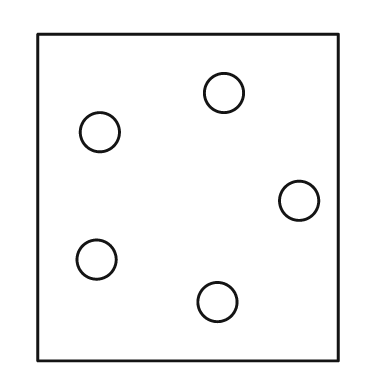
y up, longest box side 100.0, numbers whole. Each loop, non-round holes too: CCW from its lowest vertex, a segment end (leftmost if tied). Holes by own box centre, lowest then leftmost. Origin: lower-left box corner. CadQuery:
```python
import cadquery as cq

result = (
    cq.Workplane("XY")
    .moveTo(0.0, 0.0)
    .lineTo(92.0, 0.0)
    .lineTo(92.0, 100.0)
    .lineTo(0.0, 100.0)
    .close()
    .moveTo(55.0, 18.0)
    .circle(6.0)
    .moveTo(18.0, 31.0)
    .circle(6.0)
    .moveTo(80.0, 49.0)
    .circle(6.0)
    .moveTo(19.0, 70.0)
    .circle(6.0)
    .moveTo(57.0, 82.0)
    .circle(6.0)
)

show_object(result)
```